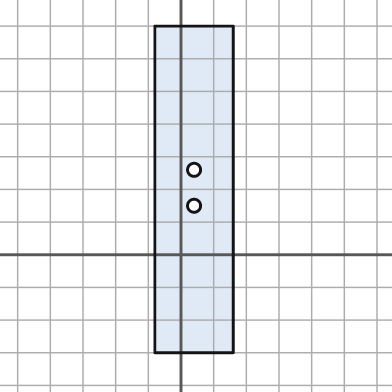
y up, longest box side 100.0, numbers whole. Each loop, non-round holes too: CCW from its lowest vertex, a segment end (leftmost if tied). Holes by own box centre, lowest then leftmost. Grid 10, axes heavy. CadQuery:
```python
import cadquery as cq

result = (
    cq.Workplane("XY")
    .moveTo(-8.0, -30.0)
    .lineTo(16.0, -30.0)
    .lineTo(16.0, 70.0)
    .lineTo(-8.0, 70.0)
    .close()
    .moveTo(4.0, 15.0)
    .circle(2.0)
    .moveTo(4.0, 26.0)
    .circle(2.0)
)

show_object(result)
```